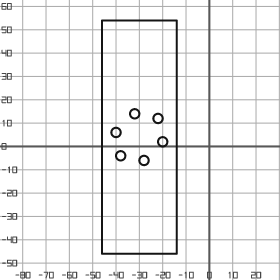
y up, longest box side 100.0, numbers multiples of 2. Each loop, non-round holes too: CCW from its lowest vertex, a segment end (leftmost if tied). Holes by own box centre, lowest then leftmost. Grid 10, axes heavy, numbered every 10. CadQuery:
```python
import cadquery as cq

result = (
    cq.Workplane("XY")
    .moveTo(-46.0, -46.0)
    .lineTo(-14.0, -46.0)
    .lineTo(-14.0, 54.0)
    .lineTo(-46.0, 54.0)
    .close()
    .moveTo(-28.0, -6.0)
    .circle(2.0)
    .moveTo(-38.0, -4.0)
    .circle(2.0)
    .moveTo(-20.0, 2.0)
    .circle(2.0)
    .moveTo(-40.0, 6.0)
    .circle(2.0)
    .moveTo(-22.0, 12.0)
    .circle(2.0)
    .moveTo(-32.0, 14.0)
    .circle(2.0)
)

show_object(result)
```